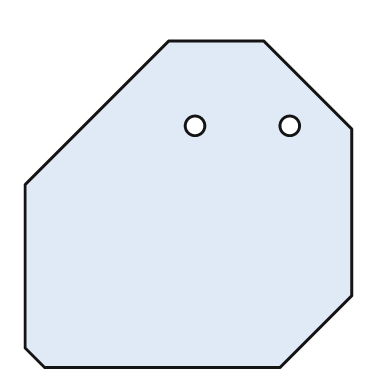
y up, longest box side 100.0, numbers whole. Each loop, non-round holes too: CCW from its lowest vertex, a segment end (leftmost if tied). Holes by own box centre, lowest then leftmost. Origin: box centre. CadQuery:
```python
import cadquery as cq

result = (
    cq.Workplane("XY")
    .moveTo(-44.0, -50.0)
    .lineTo(28.0, -50.0)
    .lineTo(50.0, -28.0)
    .lineTo(50.0, 23.0)
    .lineTo(23.0, 50.0)
    .lineTo(-6.0, 50.0)
    .lineTo(-50.0, 6.0)
    .lineTo(-50.0, -44.0)
    .close()
    .moveTo(2.0, 24.0)
    .circle(3.0)
    .moveTo(31.0, 24.0)
    .circle(3.0)
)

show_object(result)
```